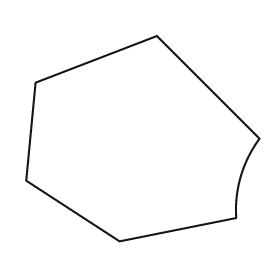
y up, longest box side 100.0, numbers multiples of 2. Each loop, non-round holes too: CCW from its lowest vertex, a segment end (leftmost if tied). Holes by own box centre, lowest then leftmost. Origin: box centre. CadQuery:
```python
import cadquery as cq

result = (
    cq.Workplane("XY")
    .moveTo(-10.0, -44.0)
    .lineTo(40.0, -34.0)
    .threePointArc((42.0, -16.0), (50.0, 0.0))
    .lineTo(6.0, 44.0)
    .lineTo(-46.0, 24.0)
    .lineTo(-50.0, -18.0)
    .close()
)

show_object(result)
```